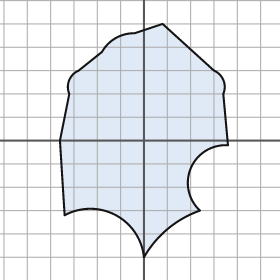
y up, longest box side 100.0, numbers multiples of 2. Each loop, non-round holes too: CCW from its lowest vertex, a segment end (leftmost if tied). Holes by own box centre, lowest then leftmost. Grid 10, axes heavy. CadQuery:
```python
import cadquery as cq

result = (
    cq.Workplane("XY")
    .moveTo(0.0, -50.0)
    .threePointArc((10.0, -38.0), (24.0, -30.0))
    .threePointArc((20.0, -12.0), (36.0, -2.0))
    .lineTo(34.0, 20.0)
    .threePointArc((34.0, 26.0), (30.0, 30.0))
    .lineTo(8.0, 50.0)
    .lineTo(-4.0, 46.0)
    .threePointArc((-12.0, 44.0), (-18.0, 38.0))
    .lineTo(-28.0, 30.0)
    .threePointArc((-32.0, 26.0), (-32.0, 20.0))
    .lineTo(-36.0, 0.0)
    .lineTo(-34.0, -32.0)
    .threePointArc((-12.0, -32.0), (0.0, -50.0))
    .close()
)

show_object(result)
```